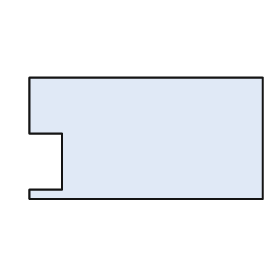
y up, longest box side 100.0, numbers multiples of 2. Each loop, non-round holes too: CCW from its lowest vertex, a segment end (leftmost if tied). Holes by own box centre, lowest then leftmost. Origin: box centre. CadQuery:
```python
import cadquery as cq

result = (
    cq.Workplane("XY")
    .moveTo(-50.0, -26.0)
    .lineTo(50.0, -26.0)
    .lineTo(50.0, 26.0)
    .lineTo(-50.0, 26.0)
    .lineTo(-50.0, 2.0)
    .lineTo(-36.0, 2.0)
    .lineTo(-36.0, -22.0)
    .lineTo(-50.0, -22.0)
    .close()
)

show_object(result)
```